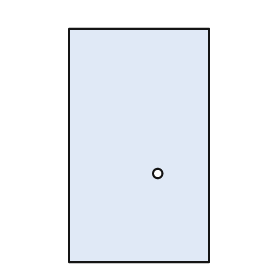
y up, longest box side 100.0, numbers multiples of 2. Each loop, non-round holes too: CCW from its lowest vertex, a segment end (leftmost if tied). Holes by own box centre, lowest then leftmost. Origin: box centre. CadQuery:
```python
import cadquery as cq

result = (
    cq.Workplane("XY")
    .moveTo(-30.0, -50.0)
    .lineTo(30.0, -50.0)
    .lineTo(30.0, 50.0)
    .lineTo(-30.0, 50.0)
    .close()
    .moveTo(8.0, -12.0)
    .circle(2.0)
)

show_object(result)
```